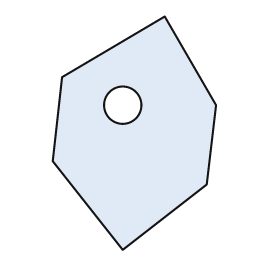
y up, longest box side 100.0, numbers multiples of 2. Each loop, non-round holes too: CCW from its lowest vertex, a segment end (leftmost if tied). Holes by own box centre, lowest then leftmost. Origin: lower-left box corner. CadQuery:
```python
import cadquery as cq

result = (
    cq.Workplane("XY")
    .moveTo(30.0, 0.0)
    .lineTo(66.0, 28.0)
    .lineTo(70.0, 62.0)
    .lineTo(48.0, 100.0)
    .lineTo(4.0, 74.0)
    .lineTo(0.0, 38.0)
    .close()
    .moveTo(30.0, 62.0)
    .circle(8.0)
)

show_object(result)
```